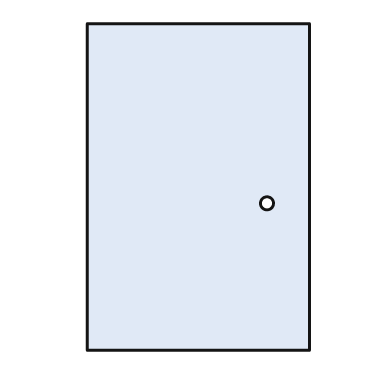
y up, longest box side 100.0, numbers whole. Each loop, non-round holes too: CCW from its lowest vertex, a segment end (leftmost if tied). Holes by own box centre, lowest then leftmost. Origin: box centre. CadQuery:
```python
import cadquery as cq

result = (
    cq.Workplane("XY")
    .moveTo(-34.0, -50.0)
    .lineTo(34.0, -50.0)
    .lineTo(34.0, 50.0)
    .lineTo(-34.0, 50.0)
    .close()
    .moveTo(21.0, -5.0)
    .circle(2.0)
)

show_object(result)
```